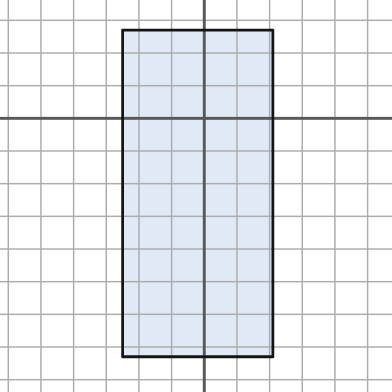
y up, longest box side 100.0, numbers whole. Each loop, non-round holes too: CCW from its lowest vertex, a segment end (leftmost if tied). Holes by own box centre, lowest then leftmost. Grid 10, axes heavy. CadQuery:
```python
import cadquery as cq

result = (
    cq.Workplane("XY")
    .moveTo(-25.0, -73.0)
    .lineTo(21.0, -73.0)
    .lineTo(21.0, 27.0)
    .lineTo(-25.0, 27.0)
    .close()
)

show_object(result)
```